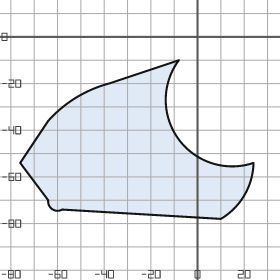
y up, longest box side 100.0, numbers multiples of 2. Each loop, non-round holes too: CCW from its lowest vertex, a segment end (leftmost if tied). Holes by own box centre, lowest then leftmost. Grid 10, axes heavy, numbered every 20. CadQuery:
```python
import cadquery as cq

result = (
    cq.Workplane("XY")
    .moveTo(10.0, -78.0)
    .threePointArc((20.0, -68.0), (24.0, -54.0))
    .threePointArc((-8.0, -44.0), (-8.0, -10.0))
    .lineTo(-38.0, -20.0)
    .threePointArc((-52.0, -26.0), (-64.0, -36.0))
    .lineTo(-76.0, -54.0)
    .lineTo(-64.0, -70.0)
    .threePointArc((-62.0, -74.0), (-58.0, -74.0))
    .close()
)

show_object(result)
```